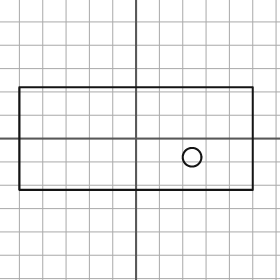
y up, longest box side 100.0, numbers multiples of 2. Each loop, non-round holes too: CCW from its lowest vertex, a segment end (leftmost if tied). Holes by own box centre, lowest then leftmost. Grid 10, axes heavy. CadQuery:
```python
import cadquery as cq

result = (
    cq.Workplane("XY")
    .moveTo(-50.0, -22.0)
    .lineTo(50.0, -22.0)
    .lineTo(50.0, 22.0)
    .lineTo(-50.0, 22.0)
    .close()
    .moveTo(24.0, -8.0)
    .circle(4.0)
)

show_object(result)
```